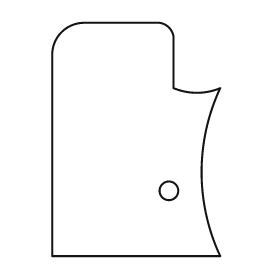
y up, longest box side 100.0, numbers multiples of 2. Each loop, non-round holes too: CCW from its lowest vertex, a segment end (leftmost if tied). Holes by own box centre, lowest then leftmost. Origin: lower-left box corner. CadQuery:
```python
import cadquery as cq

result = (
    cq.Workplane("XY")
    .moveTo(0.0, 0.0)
    .lineTo(72.0, 0.0)
    .threePointArc((64.0, 36.0), (72.0, 72.0))
    .threePointArc((62.0, 70.0), (52.0, 72.0))
    .lineTo(52.0, 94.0)
    .threePointArc((50.0, 98.0), (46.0, 100.0))
    .lineTo(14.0, 100.0)
    .threePointArc((4.0, 96.0), (0.0, 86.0))
    .close()
    .moveTo(50.0, 28.0)
    .circle(4.0)
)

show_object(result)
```